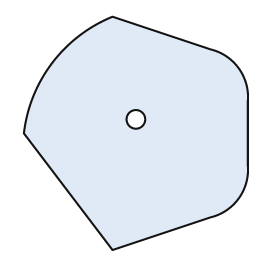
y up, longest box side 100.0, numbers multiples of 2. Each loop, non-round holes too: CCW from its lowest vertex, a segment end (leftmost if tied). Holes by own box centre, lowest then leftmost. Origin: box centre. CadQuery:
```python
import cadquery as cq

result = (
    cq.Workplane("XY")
    .moveTo(-10.0, -50.0)
    .lineTo(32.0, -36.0)
    .threePointArc((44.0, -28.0), (48.0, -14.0))
    .lineTo(48.0, 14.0)
    .threePointArc((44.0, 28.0), (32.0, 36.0))
    .lineTo(-10.0, 50.0)
    .threePointArc((-36.0, 30.0), (-48.0, 0.0))
    .close()
    .moveTo(0.0, 6.0)
    .circle(4.0)
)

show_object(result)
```